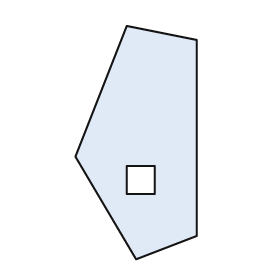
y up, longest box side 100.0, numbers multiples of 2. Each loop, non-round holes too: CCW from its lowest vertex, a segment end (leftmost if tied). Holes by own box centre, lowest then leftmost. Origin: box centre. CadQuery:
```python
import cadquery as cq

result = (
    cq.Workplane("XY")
    .moveTo(0.0, -50.0)
    .lineTo(26.0, -40.0)
    .lineTo(26.0, 44.0)
    .lineTo(-4.0, 50.0)
    .lineTo(-26.0, -6.0)
    .close()
    .moveTo(-4.0, -22.0)
    .lineTo(8.0, -22.0)
    .lineTo(8.0, -10.0)
    .lineTo(-4.0, -10.0)
    .close()
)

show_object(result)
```